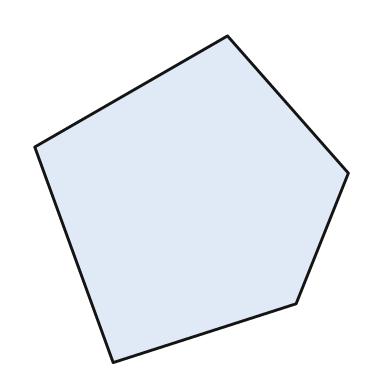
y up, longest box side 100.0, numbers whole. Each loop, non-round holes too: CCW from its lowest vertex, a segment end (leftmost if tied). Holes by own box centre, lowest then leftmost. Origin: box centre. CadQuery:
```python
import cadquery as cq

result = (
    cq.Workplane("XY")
    .moveTo(-24.0, -50.0)
    .lineTo(32.0, -32.0)
    .lineTo(48.0, 8.0)
    .lineTo(11.0, 50.0)
    .lineTo(-48.0, 16.0)
    .close()
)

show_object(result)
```